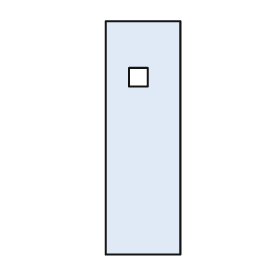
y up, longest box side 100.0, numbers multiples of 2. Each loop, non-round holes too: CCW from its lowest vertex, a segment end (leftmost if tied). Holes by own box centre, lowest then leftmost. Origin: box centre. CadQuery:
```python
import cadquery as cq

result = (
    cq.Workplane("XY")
    .moveTo(-16.0, -50.0)
    .lineTo(16.0, -50.0)
    .lineTo(16.0, 50.0)
    .lineTo(-16.0, 50.0)
    .close()
    .moveTo(-6.0, 22.0)
    .lineTo(2.0, 22.0)
    .lineTo(2.0, 30.0)
    .lineTo(-6.0, 30.0)
    .close()
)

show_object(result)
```